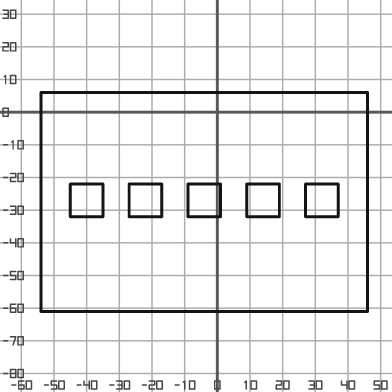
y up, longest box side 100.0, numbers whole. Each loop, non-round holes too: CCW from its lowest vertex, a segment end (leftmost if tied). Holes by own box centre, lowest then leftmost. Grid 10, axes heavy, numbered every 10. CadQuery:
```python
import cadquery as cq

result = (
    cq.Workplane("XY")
    .moveTo(-54.0, -61.0)
    .lineTo(46.0, -61.0)
    .lineTo(46.0, 6.0)
    .lineTo(-54.0, 6.0)
    .close()
    .moveTo(-45.0, -32.0)
    .lineTo(-35.0, -32.0)
    .lineTo(-35.0, -22.0)
    .lineTo(-45.0, -22.0)
    .close()
    .moveTo(-27.0, -32.0)
    .lineTo(-17.0, -32.0)
    .lineTo(-17.0, -22.0)
    .lineTo(-27.0, -22.0)
    .close()
    .moveTo(-9.0, -32.0)
    .lineTo(1.0, -32.0)
    .lineTo(1.0, -22.0)
    .lineTo(-9.0, -22.0)
    .close()
    .moveTo(9.0, -32.0)
    .lineTo(19.0, -32.0)
    .lineTo(19.0, -22.0)
    .lineTo(9.0, -22.0)
    .close()
    .moveTo(27.0, -32.0)
    .lineTo(37.0, -32.0)
    .lineTo(37.0, -22.0)
    .lineTo(27.0, -22.0)
    .close()
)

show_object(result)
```